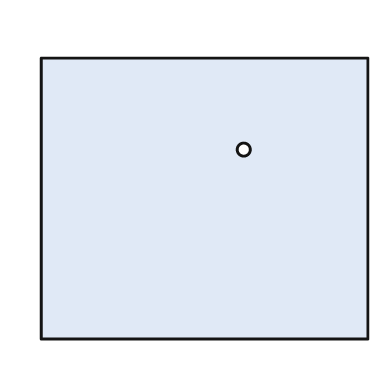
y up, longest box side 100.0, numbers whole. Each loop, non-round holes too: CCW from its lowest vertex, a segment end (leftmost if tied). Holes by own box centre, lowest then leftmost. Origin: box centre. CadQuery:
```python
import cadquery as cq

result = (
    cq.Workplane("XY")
    .moveTo(-50.0, -43.0)
    .lineTo(50.0, -43.0)
    .lineTo(50.0, 43.0)
    .lineTo(-50.0, 43.0)
    .close()
    .moveTo(12.0, 15.0)
    .circle(2.0)
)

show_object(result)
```